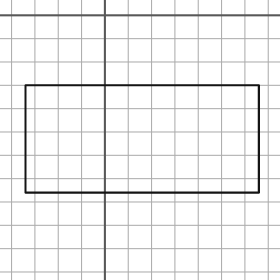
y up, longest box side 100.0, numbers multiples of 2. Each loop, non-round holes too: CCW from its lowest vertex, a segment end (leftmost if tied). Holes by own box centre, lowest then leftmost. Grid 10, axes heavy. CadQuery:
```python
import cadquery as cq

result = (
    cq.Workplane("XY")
    .moveTo(-34.0, -76.0)
    .lineTo(66.0, -76.0)
    .lineTo(66.0, -30.0)
    .lineTo(-34.0, -30.0)
    .close()
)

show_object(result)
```